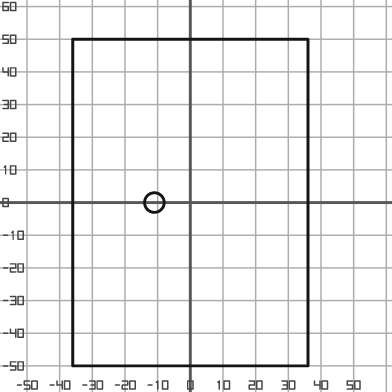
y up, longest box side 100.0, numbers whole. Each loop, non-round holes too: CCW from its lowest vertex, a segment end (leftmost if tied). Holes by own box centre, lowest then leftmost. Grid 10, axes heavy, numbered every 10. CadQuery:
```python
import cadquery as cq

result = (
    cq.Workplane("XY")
    .moveTo(-36.0, -50.0)
    .lineTo(36.0, -50.0)
    .lineTo(36.0, 50.0)
    .lineTo(-36.0, 50.0)
    .close()
    .moveTo(-11.0, 0.0)
    .circle(3.0)
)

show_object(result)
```